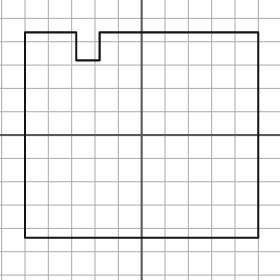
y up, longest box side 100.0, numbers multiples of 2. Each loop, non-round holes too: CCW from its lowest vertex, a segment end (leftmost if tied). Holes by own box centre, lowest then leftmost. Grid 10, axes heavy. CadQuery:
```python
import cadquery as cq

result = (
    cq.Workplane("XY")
    .moveTo(-50.0, -44.0)
    .lineTo(50.0, -44.0)
    .lineTo(50.0, 44.0)
    .lineTo(-18.0, 44.0)
    .lineTo(-18.0, 32.0)
    .lineTo(-28.0, 32.0)
    .lineTo(-28.0, 44.0)
    .lineTo(-50.0, 44.0)
    .close()
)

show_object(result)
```